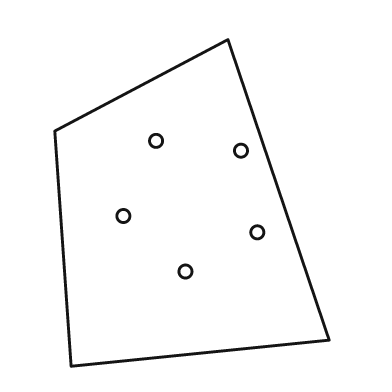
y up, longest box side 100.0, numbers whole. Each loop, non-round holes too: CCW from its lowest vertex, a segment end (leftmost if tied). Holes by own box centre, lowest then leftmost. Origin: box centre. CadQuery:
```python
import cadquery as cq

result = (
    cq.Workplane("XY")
    .moveTo(-37.0, -50.0)
    .lineTo(42.0, -42.0)
    .lineTo(11.0, 50.0)
    .lineTo(-42.0, 22.0)
    .close()
    .moveTo(-2.0, -21.0)
    .circle(2.0)
    .moveTo(20.0, -9.0)
    .circle(2.0)
    .moveTo(-21.0, -4.0)
    .circle(2.0)
    .moveTo(15.0, 16.0)
    .circle(2.0)
    .moveTo(-11.0, 19.0)
    .circle(2.0)
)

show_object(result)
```